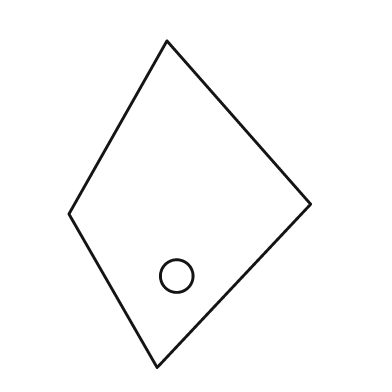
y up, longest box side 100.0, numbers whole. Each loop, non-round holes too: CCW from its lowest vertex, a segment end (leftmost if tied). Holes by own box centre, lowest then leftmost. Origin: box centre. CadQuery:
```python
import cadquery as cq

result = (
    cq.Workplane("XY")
    .moveTo(-10.0, -50.0)
    .lineTo(37.0, 0.0)
    .lineTo(-7.0, 50.0)
    .lineTo(-37.0, -3.0)
    .close()
    .moveTo(-4.0, -22.0)
    .circle(5.0)
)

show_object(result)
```